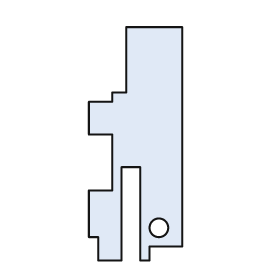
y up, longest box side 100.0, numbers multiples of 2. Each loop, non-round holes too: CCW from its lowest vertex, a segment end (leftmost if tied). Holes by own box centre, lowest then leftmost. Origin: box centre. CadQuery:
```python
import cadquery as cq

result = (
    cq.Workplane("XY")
    .moveTo(-16.0, -50.0)
    .lineTo(-6.0, -50.0)
    .lineTo(-6.0, -10.0)
    .lineTo(2.0, -10.0)
    .lineTo(2.0, -50.0)
    .lineTo(6.0, -50.0)
    .lineTo(6.0, -44.0)
    .lineTo(20.0, -44.0)
    .lineTo(20.0, 50.0)
    .lineTo(-4.0, 50.0)
    .lineTo(-4.0, 22.0)
    .lineTo(-10.0, 22.0)
    .lineTo(-10.0, 18.0)
    .lineTo(-20.0, 18.0)
    .lineTo(-20.0, 4.0)
    .lineTo(-10.0, 4.0)
    .lineTo(-10.0, -20.0)
    .lineTo(-20.0, -20.0)
    .lineTo(-20.0, -40.0)
    .lineTo(-16.0, -40.0)
    .close()
    .moveTo(10.0, -36.0)
    .circle(4.0)
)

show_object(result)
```